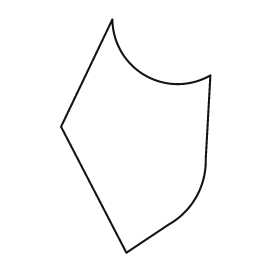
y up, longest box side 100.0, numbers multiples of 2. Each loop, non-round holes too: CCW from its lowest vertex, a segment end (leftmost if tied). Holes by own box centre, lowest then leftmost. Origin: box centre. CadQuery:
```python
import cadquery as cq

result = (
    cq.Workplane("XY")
    .moveTo(-4.0, -50.0)
    .lineTo(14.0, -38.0)
    .threePointArc((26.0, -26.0), (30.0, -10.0))
    .lineTo(32.0, 26.0)
    .threePointArc((4.0, 26.0), (-10.0, 50.0))
    .lineTo(-32.0, 4.0)
    .close()
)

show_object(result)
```